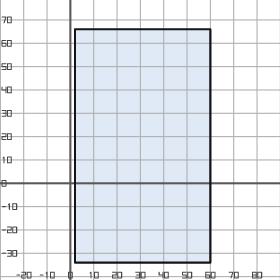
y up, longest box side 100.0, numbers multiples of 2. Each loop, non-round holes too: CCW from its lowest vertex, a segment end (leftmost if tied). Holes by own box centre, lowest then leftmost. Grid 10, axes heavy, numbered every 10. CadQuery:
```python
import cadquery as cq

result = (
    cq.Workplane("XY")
    .moveTo(2.0, -34.0)
    .lineTo(60.0, -34.0)
    .lineTo(60.0, 66.0)
    .lineTo(2.0, 66.0)
    .close()
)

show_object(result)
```